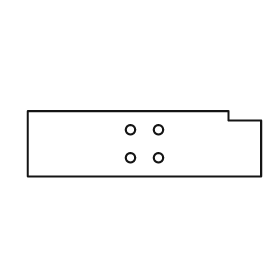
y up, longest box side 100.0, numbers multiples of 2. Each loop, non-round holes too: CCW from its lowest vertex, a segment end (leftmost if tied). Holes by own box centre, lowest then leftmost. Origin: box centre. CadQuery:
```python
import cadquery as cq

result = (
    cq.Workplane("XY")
    .moveTo(-50.0, -14.0)
    .lineTo(50.0, -14.0)
    .lineTo(50.0, 10.0)
    .lineTo(36.0, 10.0)
    .lineTo(36.0, 14.0)
    .lineTo(-50.0, 14.0)
    .close()
    .moveTo(-6.0, -6.0)
    .circle(2.0)
    .moveTo(6.0, -6.0)
    .circle(2.0)
    .moveTo(-6.0, 6.0)
    .circle(2.0)
    .moveTo(6.0, 6.0)
    .circle(2.0)
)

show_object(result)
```